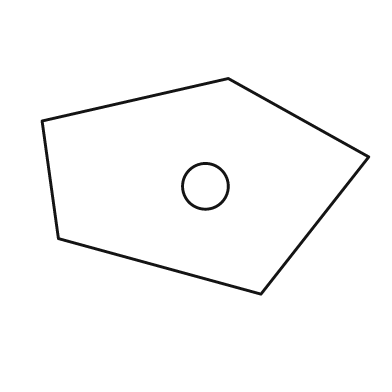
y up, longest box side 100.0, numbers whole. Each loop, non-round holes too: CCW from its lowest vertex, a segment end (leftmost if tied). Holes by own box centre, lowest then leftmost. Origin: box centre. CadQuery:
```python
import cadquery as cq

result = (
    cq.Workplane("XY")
    .moveTo(17.0, -33.0)
    .lineTo(50.0, 9.0)
    .lineTo(7.0, 33.0)
    .lineTo(-50.0, 20.0)
    .lineTo(-45.0, -16.0)
    .close()
    .moveTo(0.0, 0.0)
    .circle(7.0)
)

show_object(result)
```